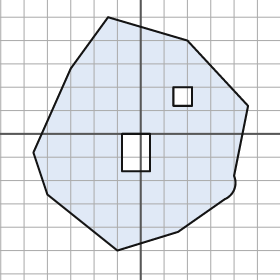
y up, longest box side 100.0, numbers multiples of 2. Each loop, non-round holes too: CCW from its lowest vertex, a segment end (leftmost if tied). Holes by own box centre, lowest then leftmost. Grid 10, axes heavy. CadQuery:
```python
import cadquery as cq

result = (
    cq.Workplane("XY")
    .moveTo(-10.0, -50.0)
    .lineTo(16.0, -42.0)
    .lineTo(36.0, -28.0)
    .threePointArc((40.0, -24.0), (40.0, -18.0))
    .lineTo(46.0, 12.0)
    .lineTo(20.0, 40.0)
    .lineTo(-14.0, 50.0)
    .lineTo(-30.0, 28.0)
    .lineTo(-46.0, -8.0)
    .lineTo(-40.0, -26.0)
    .close()
    .moveTo(-8.0, -16.0)
    .lineTo(4.0, -16.0)
    .lineTo(4.0, 0.0)
    .lineTo(-8.0, 0.0)
    .close()
    .moveTo(14.0, 12.0)
    .lineTo(22.0, 12.0)
    .lineTo(22.0, 20.0)
    .lineTo(14.0, 20.0)
    .close()
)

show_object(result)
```